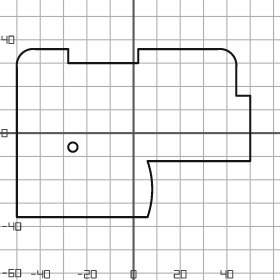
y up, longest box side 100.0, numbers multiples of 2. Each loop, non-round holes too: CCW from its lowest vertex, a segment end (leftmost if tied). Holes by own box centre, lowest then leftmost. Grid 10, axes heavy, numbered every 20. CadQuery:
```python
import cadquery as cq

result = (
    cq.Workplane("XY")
    .moveTo(-50.0, -36.0)
    .lineTo(6.0, -36.0)
    .threePointArc((8.0, -24.0), (6.0, -12.0))
    .lineTo(50.0, -12.0)
    .lineTo(50.0, 16.0)
    .lineTo(44.0, 16.0)
    .lineTo(44.0, 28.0)
    .threePointArc((42.0, 34.0), (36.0, 36.0))
    .lineTo(2.0, 36.0)
    .lineTo(2.0, 30.0)
    .lineTo(-28.0, 30.0)
    .lineTo(-28.0, 36.0)
    .lineTo(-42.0, 36.0)
    .threePointArc((-48.0, 34.0), (-50.0, 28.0))
    .close()
    .moveTo(-26.0, -6.0)
    .circle(2.0)
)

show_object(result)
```